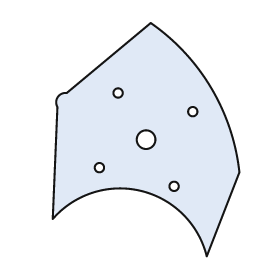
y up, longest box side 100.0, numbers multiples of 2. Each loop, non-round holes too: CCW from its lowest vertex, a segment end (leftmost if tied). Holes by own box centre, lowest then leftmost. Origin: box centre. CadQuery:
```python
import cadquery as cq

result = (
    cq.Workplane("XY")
    .moveTo(26.0, -50.0)
    .lineTo(40.0, -14.0)
    .threePointArc((28.0, 22.0), (2.0, 50.0))
    .lineTo(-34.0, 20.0)
    .threePointArc((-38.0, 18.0), (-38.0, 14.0))
    .lineTo(-40.0, -34.0)
    .threePointArc((-2.0, -22.0), (26.0, -50.0))
    .close()
    .moveTo(12.0, -20.0)
    .circle(2.0)
    .moveTo(-20.0, -12.0)
    .circle(2.0)
    .moveTo(0.0, 0.0)
    .circle(4.0)
    .moveTo(20.0, 12.0)
    .circle(2.0)
    .moveTo(-12.0, 20.0)
    .circle(2.0)
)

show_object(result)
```